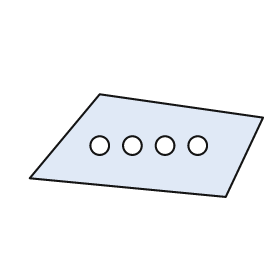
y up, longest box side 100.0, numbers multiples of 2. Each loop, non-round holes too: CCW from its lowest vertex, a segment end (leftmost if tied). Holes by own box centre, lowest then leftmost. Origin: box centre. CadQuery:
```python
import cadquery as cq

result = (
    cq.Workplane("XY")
    .moveTo(34.0, -22.0)
    .lineTo(50.0, 12.0)
    .lineTo(-20.0, 22.0)
    .lineTo(-50.0, -14.0)
    .close()
    .moveTo(-20.0, 0.0)
    .circle(4.0)
    .moveTo(-6.0, 0.0)
    .circle(4.0)
    .moveTo(8.0, 0.0)
    .circle(4.0)
    .moveTo(22.0, 0.0)
    .circle(4.0)
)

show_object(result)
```